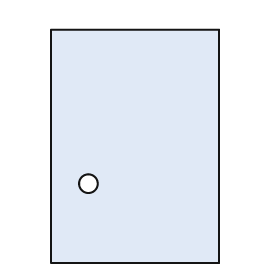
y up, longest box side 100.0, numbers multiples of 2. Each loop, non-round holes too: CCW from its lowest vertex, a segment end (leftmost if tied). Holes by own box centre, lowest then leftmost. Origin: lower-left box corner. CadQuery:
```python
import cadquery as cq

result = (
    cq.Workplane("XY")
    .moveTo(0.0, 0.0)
    .lineTo(72.0, 0.0)
    .lineTo(72.0, 100.0)
    .lineTo(0.0, 100.0)
    .close()
    .moveTo(16.0, 34.0)
    .circle(4.0)
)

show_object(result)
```